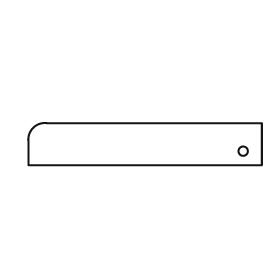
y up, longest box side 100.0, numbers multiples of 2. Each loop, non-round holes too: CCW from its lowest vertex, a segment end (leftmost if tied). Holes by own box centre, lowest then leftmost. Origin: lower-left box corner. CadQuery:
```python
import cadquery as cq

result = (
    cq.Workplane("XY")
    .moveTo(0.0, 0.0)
    .lineTo(100.0, 0.0)
    .lineTo(100.0, 18.0)
    .lineTo(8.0, 18.0)
    .threePointArc((2.0, 16.0), (0.0, 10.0))
    .close()
    .moveTo(92.0, 6.0)
    .circle(2.0)
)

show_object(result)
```